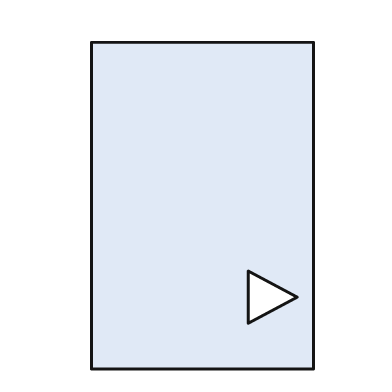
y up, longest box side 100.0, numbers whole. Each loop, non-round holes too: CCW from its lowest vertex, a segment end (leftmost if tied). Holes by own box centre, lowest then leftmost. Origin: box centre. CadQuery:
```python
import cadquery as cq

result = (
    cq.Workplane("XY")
    .moveTo(-34.0, -50.0)
    .lineTo(34.0, -50.0)
    .lineTo(34.0, 50.0)
    .lineTo(-34.0, 50.0)
    .close()
    .moveTo(14.0, -36.0)
    .lineTo(29.0, -28.0)
    .lineTo(14.0, -20.0)
    .close()
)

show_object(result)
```